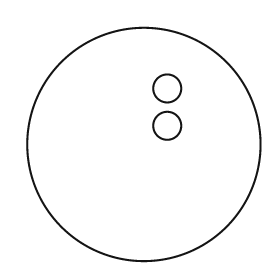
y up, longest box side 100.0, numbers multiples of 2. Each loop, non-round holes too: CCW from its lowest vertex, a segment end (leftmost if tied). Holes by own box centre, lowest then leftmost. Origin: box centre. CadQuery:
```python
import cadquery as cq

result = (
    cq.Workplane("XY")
    .moveTo(0.0, 0.0)
    .circle(50.0)
    .moveTo(10.0, 8.0)
    .circle(6.0)
    .moveTo(10.0, 24.0)
    .circle(6.0)
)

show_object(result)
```